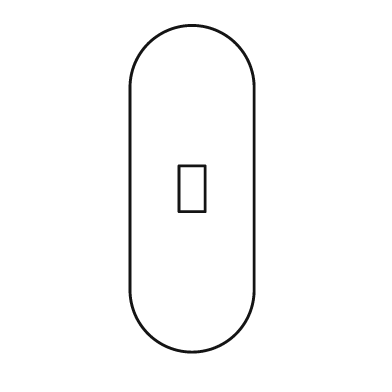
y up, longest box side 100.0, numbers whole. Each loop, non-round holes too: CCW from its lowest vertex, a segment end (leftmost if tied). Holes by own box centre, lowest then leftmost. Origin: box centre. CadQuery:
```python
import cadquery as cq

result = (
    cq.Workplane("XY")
    .moveTo(-19.0, -31.0)
    .threePointArc((0.0, -50.0), (19.0, -31.0))
    .lineTo(19.0, 31.0)
    .threePointArc((0.0, 50.0), (-19.0, 31.0))
    .close()
    .moveTo(-4.0, -7.0)
    .lineTo(4.0, -7.0)
    .lineTo(4.0, 7.0)
    .lineTo(-4.0, 7.0)
    .close()
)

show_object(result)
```